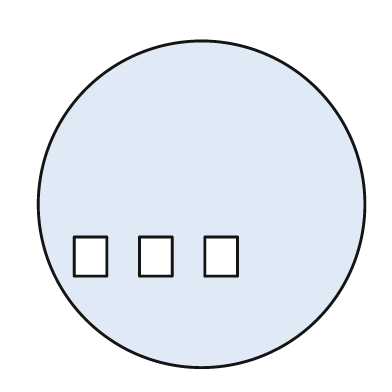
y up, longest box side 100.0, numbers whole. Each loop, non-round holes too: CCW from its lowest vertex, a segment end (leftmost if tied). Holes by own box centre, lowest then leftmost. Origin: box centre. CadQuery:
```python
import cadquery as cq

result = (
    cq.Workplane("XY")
    .moveTo(0.0, 0.0)
    .circle(50.0)
    .moveTo(-39.0, -22.0)
    .lineTo(-29.0, -22.0)
    .lineTo(-29.0, -10.0)
    .lineTo(-39.0, -10.0)
    .close()
    .moveTo(-19.0, -22.0)
    .lineTo(-9.0, -22.0)
    .lineTo(-9.0, -10.0)
    .lineTo(-19.0, -10.0)
    .close()
    .moveTo(1.0, -22.0)
    .lineTo(11.0, -22.0)
    .lineTo(11.0, -10.0)
    .lineTo(1.0, -10.0)
    .close()
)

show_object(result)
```